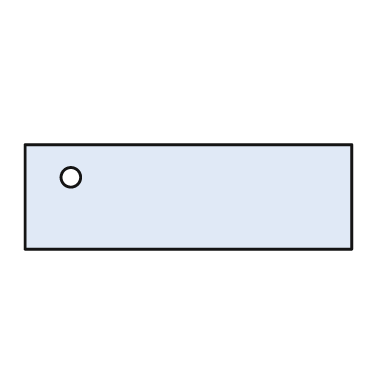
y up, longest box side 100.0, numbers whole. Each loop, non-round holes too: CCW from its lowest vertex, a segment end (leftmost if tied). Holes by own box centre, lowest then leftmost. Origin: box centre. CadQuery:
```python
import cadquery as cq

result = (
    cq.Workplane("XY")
    .moveTo(-50.0, -16.0)
    .lineTo(50.0, -16.0)
    .lineTo(50.0, 16.0)
    .lineTo(-50.0, 16.0)
    .close()
    .moveTo(-36.0, 6.0)
    .circle(3.0)
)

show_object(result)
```